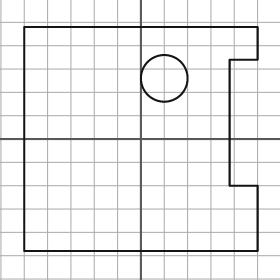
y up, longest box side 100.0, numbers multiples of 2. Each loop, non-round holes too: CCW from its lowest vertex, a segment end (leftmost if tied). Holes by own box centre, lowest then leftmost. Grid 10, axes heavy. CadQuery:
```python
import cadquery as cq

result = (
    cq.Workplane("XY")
    .moveTo(-50.0, -48.0)
    .lineTo(50.0, -48.0)
    .lineTo(50.0, -20.0)
    .lineTo(38.0, -20.0)
    .lineTo(38.0, 34.0)
    .lineTo(50.0, 34.0)
    .lineTo(50.0, 48.0)
    .lineTo(-50.0, 48.0)
    .close()
    .moveTo(10.0, 26.0)
    .circle(10.0)
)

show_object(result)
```